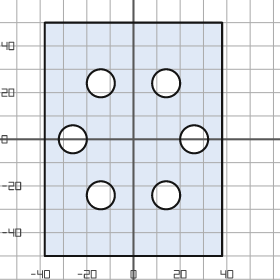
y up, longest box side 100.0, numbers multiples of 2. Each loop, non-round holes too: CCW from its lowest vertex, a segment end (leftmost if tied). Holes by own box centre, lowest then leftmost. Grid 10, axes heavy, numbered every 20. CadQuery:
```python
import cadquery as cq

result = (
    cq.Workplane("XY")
    .moveTo(-38.0, -50.0)
    .lineTo(38.0, -50.0)
    .lineTo(38.0, 50.0)
    .lineTo(-38.0, 50.0)
    .close()
    .moveTo(-14.0, -24.0)
    .circle(6.0)
    .moveTo(14.0, -24.0)
    .circle(6.0)
    .moveTo(-26.0, 0.0)
    .circle(6.0)
    .moveTo(26.0, 0.0)
    .circle(6.0)
    .moveTo(-14.0, 24.0)
    .circle(6.0)
    .moveTo(14.0, 24.0)
    .circle(6.0)
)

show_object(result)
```